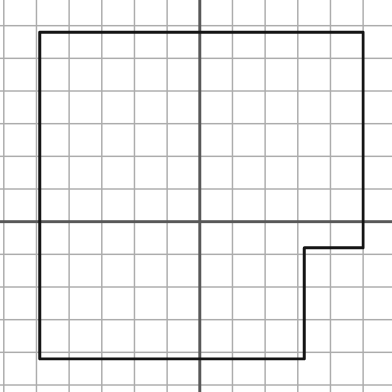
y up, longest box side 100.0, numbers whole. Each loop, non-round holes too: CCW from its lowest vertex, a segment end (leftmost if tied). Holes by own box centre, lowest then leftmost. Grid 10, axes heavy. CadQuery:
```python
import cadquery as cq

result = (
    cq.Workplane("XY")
    .moveTo(-49.0, -42.0)
    .lineTo(32.0, -42.0)
    .lineTo(32.0, -8.0)
    .lineTo(50.0, -8.0)
    .lineTo(50.0, 58.0)
    .lineTo(-49.0, 58.0)
    .close()
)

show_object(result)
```